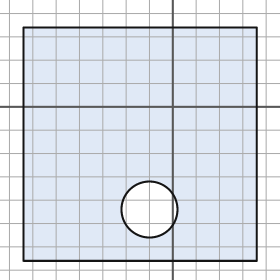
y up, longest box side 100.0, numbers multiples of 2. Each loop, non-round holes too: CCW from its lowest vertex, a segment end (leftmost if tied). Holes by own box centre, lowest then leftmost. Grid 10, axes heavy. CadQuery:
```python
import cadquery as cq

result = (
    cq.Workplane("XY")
    .moveTo(-64.0, -66.0)
    .lineTo(36.0, -66.0)
    .lineTo(36.0, 34.0)
    .lineTo(-64.0, 34.0)
    .close()
    .moveTo(-10.0, -44.0)
    .circle(12.0)
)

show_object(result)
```